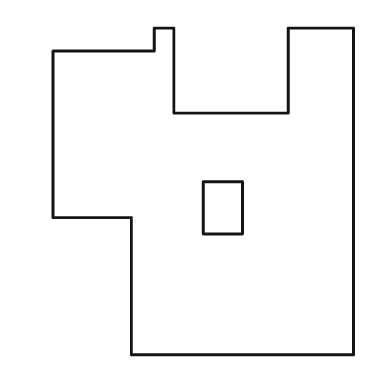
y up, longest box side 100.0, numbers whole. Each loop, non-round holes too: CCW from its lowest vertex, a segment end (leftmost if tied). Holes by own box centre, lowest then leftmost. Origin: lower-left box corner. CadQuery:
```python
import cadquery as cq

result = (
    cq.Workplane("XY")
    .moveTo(24.0, 0.0)
    .lineTo(92.0, 0.0)
    .lineTo(92.0, 100.0)
    .lineTo(72.0, 100.0)
    .lineTo(72.0, 74.0)
    .lineTo(37.0, 74.0)
    .lineTo(37.0, 100.0)
    .lineTo(31.0, 100.0)
    .lineTo(31.0, 93.0)
    .lineTo(0.0, 93.0)
    .lineTo(0.0, 42.0)
    .lineTo(24.0, 42.0)
    .close()
    .moveTo(46.0, 37.0)
    .lineTo(58.0, 37.0)
    .lineTo(58.0, 53.0)
    .lineTo(46.0, 53.0)
    .close()
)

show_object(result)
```